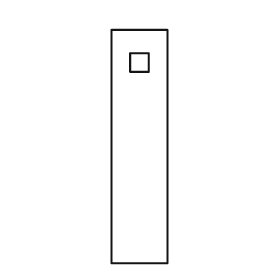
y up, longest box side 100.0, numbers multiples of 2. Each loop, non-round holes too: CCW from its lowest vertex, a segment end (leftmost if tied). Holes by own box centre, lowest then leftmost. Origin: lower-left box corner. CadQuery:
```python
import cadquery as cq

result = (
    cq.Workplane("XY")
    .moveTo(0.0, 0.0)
    .lineTo(24.0, 0.0)
    .lineTo(24.0, 100.0)
    .lineTo(0.0, 100.0)
    .close()
    .moveTo(8.0, 82.0)
    .lineTo(16.0, 82.0)
    .lineTo(16.0, 90.0)
    .lineTo(8.0, 90.0)
    .close()
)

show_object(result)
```